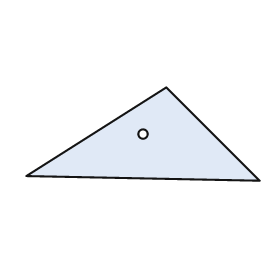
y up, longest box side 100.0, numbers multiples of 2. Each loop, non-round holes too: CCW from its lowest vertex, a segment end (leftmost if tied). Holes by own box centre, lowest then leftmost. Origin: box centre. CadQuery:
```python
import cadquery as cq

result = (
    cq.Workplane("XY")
    .moveTo(50.0, -20.0)
    .lineTo(10.0, 20.0)
    .lineTo(-50.0, -18.0)
    .close()
    .moveTo(0.0, 0.0)
    .circle(2.0)
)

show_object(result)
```